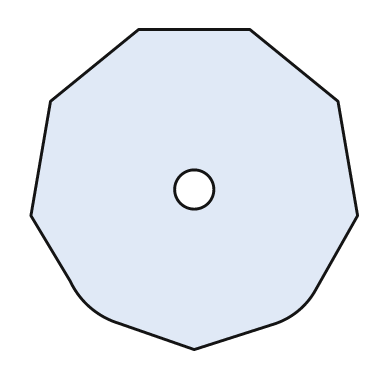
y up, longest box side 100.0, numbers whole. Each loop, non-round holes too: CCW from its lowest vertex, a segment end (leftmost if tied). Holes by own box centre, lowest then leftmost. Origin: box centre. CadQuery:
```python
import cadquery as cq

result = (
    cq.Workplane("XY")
    .moveTo(0.0, -49.0)
    .lineTo(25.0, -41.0)
    .threePointArc((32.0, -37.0), (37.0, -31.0))
    .lineTo(50.0, -8.0)
    .lineTo(44.0, 27.0)
    .lineTo(17.0, 49.0)
    .lineTo(-17.0, 49.0)
    .lineTo(-44.0, 27.0)
    .lineTo(-50.0, -8.0)
    .lineTo(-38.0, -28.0)
    .threePointArc((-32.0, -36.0), (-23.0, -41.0))
    .close()
    .moveTo(0.0, 0.0)
    .circle(6.0)
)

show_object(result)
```